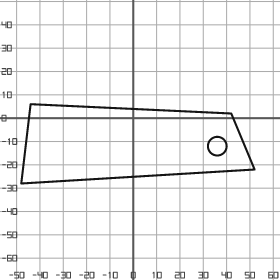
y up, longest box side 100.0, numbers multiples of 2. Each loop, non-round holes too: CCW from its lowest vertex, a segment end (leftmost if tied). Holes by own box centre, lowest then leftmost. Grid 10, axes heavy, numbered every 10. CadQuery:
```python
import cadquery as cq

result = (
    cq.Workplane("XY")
    .moveTo(-48.0, -28.0)
    .lineTo(52.0, -22.0)
    .lineTo(42.0, 2.0)
    .lineTo(-44.0, 6.0)
    .close()
    .moveTo(36.0, -12.0)
    .circle(4.0)
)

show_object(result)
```